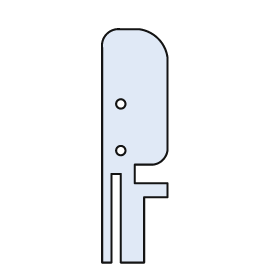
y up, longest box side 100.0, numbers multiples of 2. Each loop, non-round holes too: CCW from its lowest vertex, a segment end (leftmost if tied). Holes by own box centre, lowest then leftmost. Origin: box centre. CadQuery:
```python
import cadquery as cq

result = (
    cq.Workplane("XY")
    .moveTo(-14.0, -50.0)
    .lineTo(-10.0, -50.0)
    .lineTo(-10.0, -12.0)
    .lineTo(-6.0, -12.0)
    .lineTo(-6.0, -50.0)
    .lineTo(4.0, -50.0)
    .lineTo(4.0, -22.0)
    .lineTo(14.0, -22.0)
    .lineTo(14.0, -16.0)
    .lineTo(0.0, -16.0)
    .lineTo(0.0, -8.0)
    .lineTo(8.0, -8.0)
    .threePointArc((12.0, -6.0), (14.0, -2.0))
    .lineTo(14.0, 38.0)
    .threePointArc((10.0, 46.0), (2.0, 50.0))
    .lineTo(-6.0, 50.0)
    .threePointArc((-12.0, 48.0), (-14.0, 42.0))
    .close()
    .moveTo(-6.0, -2.0)
    .circle(2.0)
    .moveTo(-6.0, 18.0)
    .circle(2.0)
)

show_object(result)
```